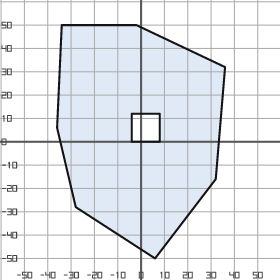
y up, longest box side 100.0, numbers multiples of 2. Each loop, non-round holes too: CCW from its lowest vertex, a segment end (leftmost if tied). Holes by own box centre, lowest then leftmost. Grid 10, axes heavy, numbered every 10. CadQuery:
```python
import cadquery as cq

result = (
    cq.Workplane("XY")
    .moveTo(6.0, -50.0)
    .lineTo(32.0, -16.0)
    .lineTo(36.0, 32.0)
    .lineTo(-2.0, 50.0)
    .lineTo(-34.0, 50.0)
    .lineTo(-36.0, 6.0)
    .lineTo(-28.0, -28.0)
    .close()
    .moveTo(-4.0, 0.0)
    .lineTo(8.0, 0.0)
    .lineTo(8.0, 12.0)
    .lineTo(-4.0, 12.0)
    .close()
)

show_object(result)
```